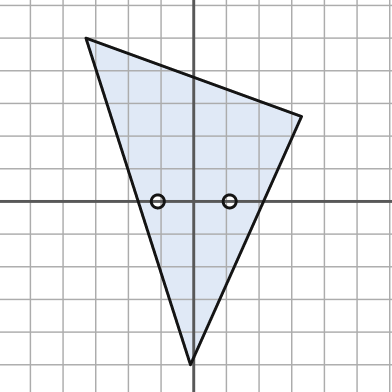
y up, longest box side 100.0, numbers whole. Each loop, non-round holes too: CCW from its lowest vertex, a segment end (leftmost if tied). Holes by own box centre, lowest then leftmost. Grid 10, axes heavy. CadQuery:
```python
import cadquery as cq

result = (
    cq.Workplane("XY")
    .moveTo(-1.0, -50.0)
    .lineTo(33.0, 26.0)
    .lineTo(-33.0, 50.0)
    .close()
    .moveTo(-11.0, 0.0)
    .circle(2.0)
    .moveTo(11.0, 0.0)
    .circle(2.0)
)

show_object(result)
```